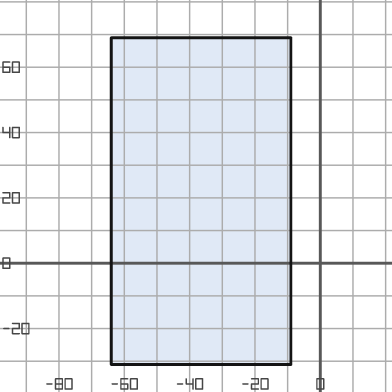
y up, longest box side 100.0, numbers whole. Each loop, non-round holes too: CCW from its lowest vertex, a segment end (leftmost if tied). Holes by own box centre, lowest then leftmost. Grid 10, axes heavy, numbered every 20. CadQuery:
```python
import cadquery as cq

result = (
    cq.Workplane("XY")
    .moveTo(-64.0, -31.0)
    .lineTo(-9.0, -31.0)
    .lineTo(-9.0, 69.0)
    .lineTo(-64.0, 69.0)
    .close()
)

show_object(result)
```